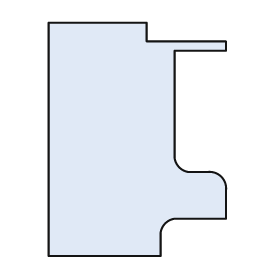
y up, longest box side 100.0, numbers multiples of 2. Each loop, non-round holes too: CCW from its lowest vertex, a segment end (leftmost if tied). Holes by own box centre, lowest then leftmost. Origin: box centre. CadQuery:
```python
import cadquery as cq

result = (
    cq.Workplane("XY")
    .moveTo(-38.0, -50.0)
    .lineTo(10.0, -50.0)
    .lineTo(10.0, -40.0)
    .threePointArc((12.0, -36.0), (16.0, -34.0))
    .lineTo(38.0, -34.0)
    .lineTo(38.0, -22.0)
    .threePointArc((36.0, -16.0), (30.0, -14.0))
    .lineTo(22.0, -14.0)
    .threePointArc((18.0, -12.0), (16.0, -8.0))
    .lineTo(16.0, 38.0)
    .lineTo(38.0, 38.0)
    .lineTo(38.0, 42.0)
    .lineTo(4.0, 42.0)
    .lineTo(4.0, 50.0)
    .lineTo(-38.0, 50.0)
    .close()
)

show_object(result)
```